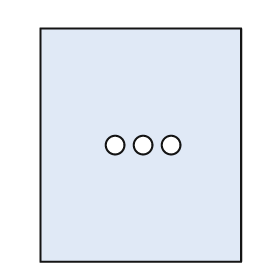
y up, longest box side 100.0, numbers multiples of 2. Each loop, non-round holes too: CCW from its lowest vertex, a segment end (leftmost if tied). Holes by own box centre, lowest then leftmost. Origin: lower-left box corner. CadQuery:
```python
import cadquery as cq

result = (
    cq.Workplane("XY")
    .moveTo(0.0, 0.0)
    .lineTo(86.0, 0.0)
    .lineTo(86.0, 100.0)
    .lineTo(0.0, 100.0)
    .close()
    .moveTo(32.0, 50.0)
    .circle(4.0)
    .moveTo(44.0, 50.0)
    .circle(4.0)
    .moveTo(56.0, 50.0)
    .circle(4.0)
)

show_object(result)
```